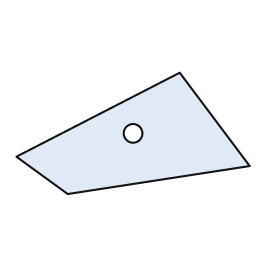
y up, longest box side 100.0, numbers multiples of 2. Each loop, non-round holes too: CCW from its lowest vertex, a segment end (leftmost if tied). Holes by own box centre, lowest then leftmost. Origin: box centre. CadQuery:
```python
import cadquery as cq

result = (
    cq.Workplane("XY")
    .moveTo(-28.0, -26.0)
    .lineTo(50.0, -14.0)
    .lineTo(20.0, 26.0)
    .lineTo(-50.0, -10.0)
    .close()
    .moveTo(0.0, 0.0)
    .circle(4.0)
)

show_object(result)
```